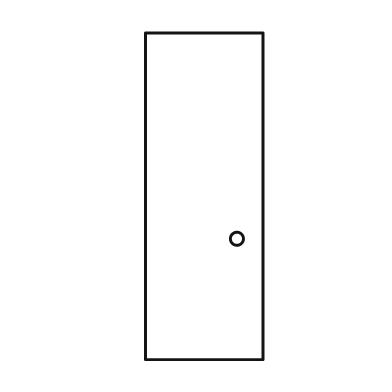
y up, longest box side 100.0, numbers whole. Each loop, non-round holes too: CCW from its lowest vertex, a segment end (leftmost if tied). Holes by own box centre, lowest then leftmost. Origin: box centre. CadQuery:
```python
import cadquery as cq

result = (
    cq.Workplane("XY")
    .moveTo(-18.0, -50.0)
    .lineTo(18.0, -50.0)
    .lineTo(18.0, 50.0)
    .lineTo(-18.0, 50.0)
    .close()
    .moveTo(10.0, -13.0)
    .circle(2.0)
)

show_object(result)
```